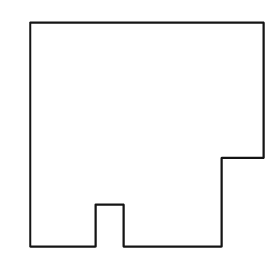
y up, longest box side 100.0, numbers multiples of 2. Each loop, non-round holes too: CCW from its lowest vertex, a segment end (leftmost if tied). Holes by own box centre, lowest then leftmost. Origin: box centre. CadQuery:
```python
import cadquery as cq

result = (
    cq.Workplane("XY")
    .moveTo(-50.0, -48.0)
    .lineTo(-22.0, -48.0)
    .lineTo(-22.0, -30.0)
    .lineTo(-10.0, -30.0)
    .lineTo(-10.0, -48.0)
    .lineTo(32.0, -48.0)
    .lineTo(32.0, -10.0)
    .lineTo(50.0, -10.0)
    .lineTo(50.0, 48.0)
    .lineTo(-50.0, 48.0)
    .close()
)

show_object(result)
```